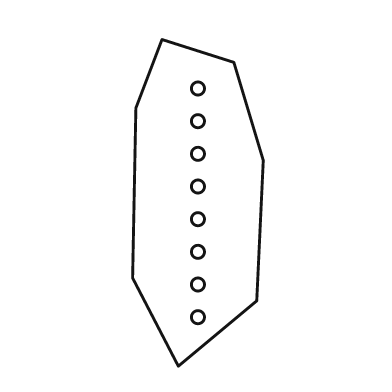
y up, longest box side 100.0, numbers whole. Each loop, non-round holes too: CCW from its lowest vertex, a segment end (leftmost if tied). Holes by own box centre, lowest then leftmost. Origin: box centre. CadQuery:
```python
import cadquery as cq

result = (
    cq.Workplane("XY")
    .moveTo(-6.0, -50.0)
    .lineTo(18.0, -30.0)
    .lineTo(20.0, 13.0)
    .lineTo(11.0, 43.0)
    .lineTo(-11.0, 50.0)
    .lineTo(-19.0, 29.0)
    .lineTo(-20.0, -23.0)
    .close()
    .moveTo(0.0, -35.0)
    .circle(2.0)
    .moveTo(0.0, -25.0)
    .circle(2.0)
    .moveTo(0.0, -15.0)
    .circle(2.0)
    .moveTo(0.0, -5.0)
    .circle(2.0)
    .moveTo(0.0, 5.0)
    .circle(2.0)
    .moveTo(0.0, 15.0)
    .circle(2.0)
    .moveTo(0.0, 25.0)
    .circle(2.0)
    .moveTo(0.0, 35.0)
    .circle(2.0)
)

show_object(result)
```